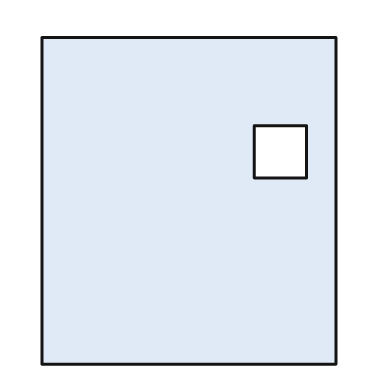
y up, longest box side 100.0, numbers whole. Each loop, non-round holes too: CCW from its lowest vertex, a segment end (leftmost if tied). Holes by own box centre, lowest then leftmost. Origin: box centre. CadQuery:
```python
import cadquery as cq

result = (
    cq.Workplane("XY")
    .moveTo(-45.0, -50.0)
    .lineTo(45.0, -50.0)
    .lineTo(45.0, 50.0)
    .lineTo(-45.0, 50.0)
    .close()
    .moveTo(20.0, 7.0)
    .lineTo(36.0, 7.0)
    .lineTo(36.0, 23.0)
    .lineTo(20.0, 23.0)
    .close()
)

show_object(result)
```